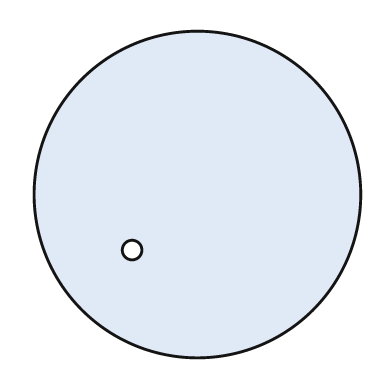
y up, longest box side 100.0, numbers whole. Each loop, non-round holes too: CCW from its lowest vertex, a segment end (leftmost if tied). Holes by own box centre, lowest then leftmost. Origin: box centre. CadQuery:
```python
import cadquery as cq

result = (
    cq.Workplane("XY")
    .moveTo(0.0, 0.0)
    .circle(50.0)
    .moveTo(-20.0, -17.0)
    .circle(3.0)
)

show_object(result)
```